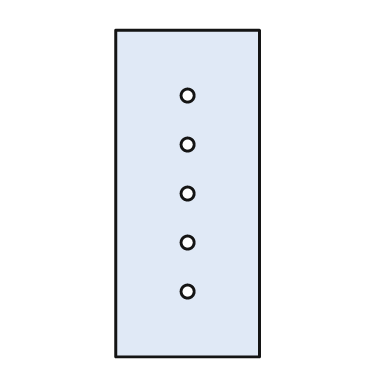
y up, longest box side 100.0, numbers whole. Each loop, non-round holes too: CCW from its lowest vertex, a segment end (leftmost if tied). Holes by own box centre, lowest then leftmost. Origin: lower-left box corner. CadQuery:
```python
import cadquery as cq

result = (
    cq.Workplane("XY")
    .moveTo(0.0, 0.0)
    .lineTo(44.0, 0.0)
    .lineTo(44.0, 100.0)
    .lineTo(0.0, 100.0)
    .close()
    .moveTo(22.0, 20.0)
    .circle(2.0)
    .moveTo(22.0, 35.0)
    .circle(2.0)
    .moveTo(22.0, 50.0)
    .circle(2.0)
    .moveTo(22.0, 65.0)
    .circle(2.0)
    .moveTo(22.0, 80.0)
    .circle(2.0)
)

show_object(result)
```